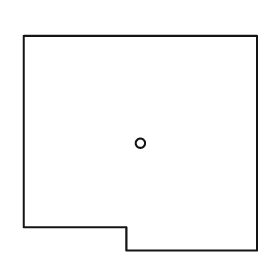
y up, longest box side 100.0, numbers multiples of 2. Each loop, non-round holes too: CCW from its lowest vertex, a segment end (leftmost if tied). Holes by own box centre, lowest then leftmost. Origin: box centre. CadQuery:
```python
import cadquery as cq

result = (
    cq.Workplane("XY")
    .moveTo(-6.0, -46.0)
    .lineTo(50.0, -46.0)
    .lineTo(50.0, 46.0)
    .lineTo(-50.0, 46.0)
    .lineTo(-50.0, -36.0)
    .lineTo(-6.0, -36.0)
    .close()
    .moveTo(0.0, 0.0)
    .circle(2.0)
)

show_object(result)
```